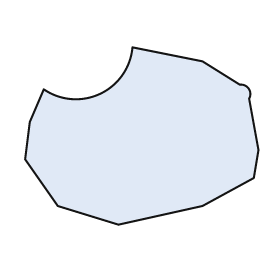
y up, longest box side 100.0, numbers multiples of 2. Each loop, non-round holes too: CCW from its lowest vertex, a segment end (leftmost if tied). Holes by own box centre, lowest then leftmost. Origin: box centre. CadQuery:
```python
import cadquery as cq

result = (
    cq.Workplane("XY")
    .moveTo(-10.0, -38.0)
    .lineTo(26.0, -30.0)
    .lineTo(48.0, -18.0)
    .lineTo(50.0, -6.0)
    .lineTo(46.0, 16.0)
    .threePointArc((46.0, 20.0), (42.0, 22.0))
    .lineTo(26.0, 32.0)
    .lineTo(-4.0, 38.0)
    .threePointArc((-18.0, 18.0), (-42.0, 20.0))
    .lineTo(-48.0, 6.0)
    .lineTo(-50.0, -10.0)
    .lineTo(-36.0, -30.0)
    .close()
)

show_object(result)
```